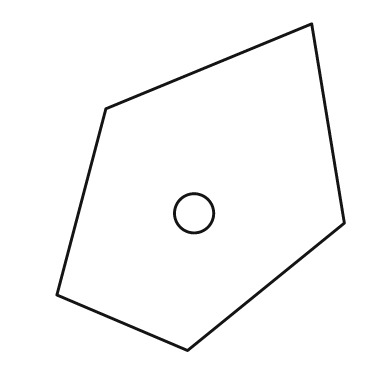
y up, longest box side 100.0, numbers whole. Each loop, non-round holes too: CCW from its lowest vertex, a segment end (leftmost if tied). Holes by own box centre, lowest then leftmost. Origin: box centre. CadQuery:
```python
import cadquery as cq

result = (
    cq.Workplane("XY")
    .moveTo(-4.0, -50.0)
    .lineTo(44.0, -11.0)
    .lineTo(34.0, 50.0)
    .lineTo(-29.0, 24.0)
    .lineTo(-44.0, -33.0)
    .close()
    .moveTo(-2.0, -8.0)
    .circle(6.0)
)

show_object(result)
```